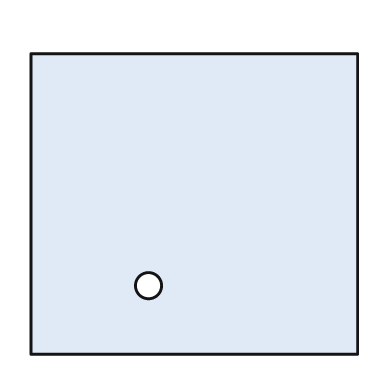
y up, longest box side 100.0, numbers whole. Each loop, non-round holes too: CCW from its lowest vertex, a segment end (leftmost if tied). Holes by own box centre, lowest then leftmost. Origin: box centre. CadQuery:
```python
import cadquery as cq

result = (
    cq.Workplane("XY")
    .moveTo(-50.0, -46.0)
    .lineTo(50.0, -46.0)
    .lineTo(50.0, 46.0)
    .lineTo(-50.0, 46.0)
    .close()
    .moveTo(-14.0, -25.0)
    .circle(4.0)
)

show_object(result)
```